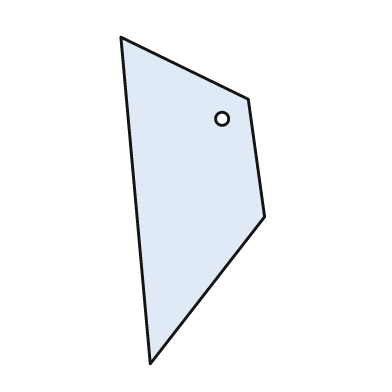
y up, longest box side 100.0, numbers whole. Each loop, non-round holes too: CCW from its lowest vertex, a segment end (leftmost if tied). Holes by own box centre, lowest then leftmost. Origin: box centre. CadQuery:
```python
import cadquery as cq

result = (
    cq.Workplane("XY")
    .moveTo(-13.0, -50.0)
    .lineTo(22.0, -5.0)
    .lineTo(17.0, 31.0)
    .lineTo(-22.0, 50.0)
    .close()
    .moveTo(9.0, 25.0)
    .circle(2.0)
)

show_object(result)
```